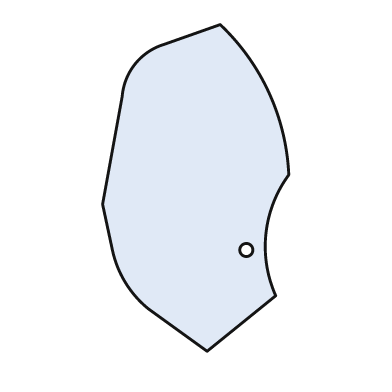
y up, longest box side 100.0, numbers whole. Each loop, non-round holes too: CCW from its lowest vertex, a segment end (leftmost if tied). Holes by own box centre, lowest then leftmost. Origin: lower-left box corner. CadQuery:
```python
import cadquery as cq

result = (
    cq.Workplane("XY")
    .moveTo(32.0, 0.0)
    .lineTo(53.0, 17.0)
    .threePointArc((50.0, 36.0), (57.0, 54.0))
    .threePointArc((51.0, 79.0), (36.0, 100.0))
    .lineTo(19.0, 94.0)
    .threePointArc((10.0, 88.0), (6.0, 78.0))
    .lineTo(0.0, 45.0)
    .lineTo(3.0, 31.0)
    .threePointArc((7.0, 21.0), (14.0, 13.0))
    .close()
    .moveTo(44.0, 31.0)
    .circle(2.0)
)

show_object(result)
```